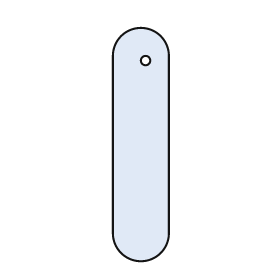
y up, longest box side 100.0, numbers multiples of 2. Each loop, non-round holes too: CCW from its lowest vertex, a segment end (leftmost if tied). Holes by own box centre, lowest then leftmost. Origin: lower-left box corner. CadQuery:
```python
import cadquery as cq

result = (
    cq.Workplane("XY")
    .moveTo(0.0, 12.0)
    .threePointArc((12.0, 0.0), (24.0, 12.0))
    .lineTo(24.0, 88.0)
    .threePointArc((12.0, 100.0), (0.0, 88.0))
    .close()
    .moveTo(14.0, 86.0)
    .circle(2.0)
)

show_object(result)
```